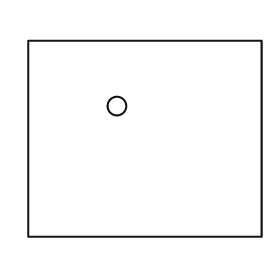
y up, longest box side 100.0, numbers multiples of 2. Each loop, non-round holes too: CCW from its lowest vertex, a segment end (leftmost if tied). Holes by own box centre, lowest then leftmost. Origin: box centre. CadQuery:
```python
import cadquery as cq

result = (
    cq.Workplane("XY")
    .moveTo(-50.0, -42.0)
    .lineTo(50.0, -42.0)
    .lineTo(50.0, 42.0)
    .lineTo(-50.0, 42.0)
    .close()
    .moveTo(-12.0, 14.0)
    .circle(4.0)
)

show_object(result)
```